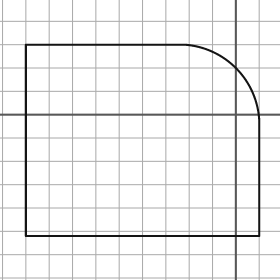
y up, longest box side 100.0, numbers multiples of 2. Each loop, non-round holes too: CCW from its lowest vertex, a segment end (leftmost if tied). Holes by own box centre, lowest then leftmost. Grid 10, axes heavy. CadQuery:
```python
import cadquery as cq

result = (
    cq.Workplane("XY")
    .moveTo(-90.0, -52.0)
    .lineTo(10.0, -52.0)
    .lineTo(10.0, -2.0)
    .threePointArc((0.0, 20.0), (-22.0, 30.0))
    .lineTo(-90.0, 30.0)
    .close()
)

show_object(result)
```